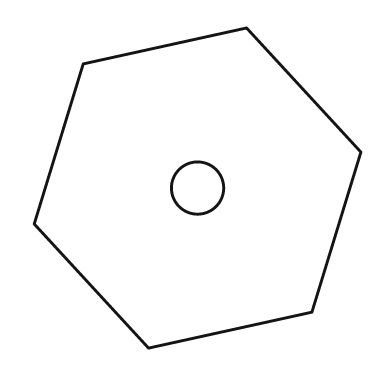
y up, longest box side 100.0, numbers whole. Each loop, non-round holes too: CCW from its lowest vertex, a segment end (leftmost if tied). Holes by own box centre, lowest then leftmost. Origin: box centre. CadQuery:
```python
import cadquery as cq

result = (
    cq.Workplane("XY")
    .moveTo(-15.0, -49.0)
    .lineTo(35.0, -38.0)
    .lineTo(50.0, 11.0)
    .lineTo(15.0, 49.0)
    .lineTo(-35.0, 38.0)
    .lineTo(-50.0, -11.0)
    .close()
    .moveTo(0.0, 0.0)
    .circle(8.0)
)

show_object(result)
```